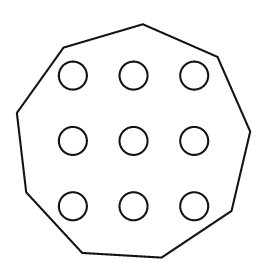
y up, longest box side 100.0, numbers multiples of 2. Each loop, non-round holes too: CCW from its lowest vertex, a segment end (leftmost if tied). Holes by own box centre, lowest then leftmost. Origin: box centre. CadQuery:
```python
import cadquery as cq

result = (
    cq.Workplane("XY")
    .moveTo(12.0, -50.0)
    .lineTo(42.0, -30.0)
    .lineTo(50.0, 4.0)
    .lineTo(36.0, 36.0)
    .lineTo(4.0, 50.0)
    .lineTo(-30.0, 40.0)
    .lineTo(-50.0, 12.0)
    .lineTo(-46.0, -22.0)
    .lineTo(-22.0, -48.0)
    .close()
    .moveTo(-26.0, -28.0)
    .circle(6.0)
    .moveTo(0.0, -28.0)
    .circle(6.0)
    .moveTo(26.0, -28.0)
    .circle(6.0)
    .moveTo(-26.0, 0.0)
    .circle(6.0)
    .moveTo(0.0, 0.0)
    .circle(6.0)
    .moveTo(26.0, 0.0)
    .circle(6.0)
    .moveTo(-26.0, 28.0)
    .circle(6.0)
    .moveTo(0.0, 28.0)
    .circle(6.0)
    .moveTo(26.0, 28.0)
    .circle(6.0)
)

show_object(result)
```